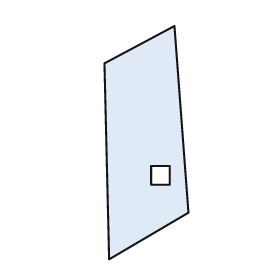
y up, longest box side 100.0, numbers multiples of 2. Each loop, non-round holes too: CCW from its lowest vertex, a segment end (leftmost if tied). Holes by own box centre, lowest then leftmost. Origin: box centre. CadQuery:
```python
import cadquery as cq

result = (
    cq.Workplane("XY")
    .moveTo(-16.0, -50.0)
    .lineTo(18.0, -30.0)
    .lineTo(12.0, 50.0)
    .lineTo(-18.0, 34.0)
    .close()
    .moveTo(2.0, -18.0)
    .lineTo(10.0, -18.0)
    .lineTo(10.0, -10.0)
    .lineTo(2.0, -10.0)
    .close()
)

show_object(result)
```